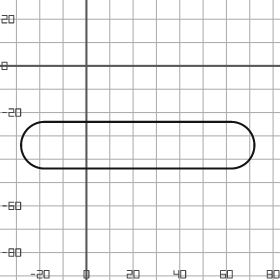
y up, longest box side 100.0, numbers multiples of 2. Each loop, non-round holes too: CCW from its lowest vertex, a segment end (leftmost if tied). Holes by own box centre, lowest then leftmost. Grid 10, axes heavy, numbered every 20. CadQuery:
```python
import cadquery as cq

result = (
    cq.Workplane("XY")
    .moveTo(-18.0, -44.0)
    .lineTo(62.0, -44.0)
    .threePointArc((72.0, -34.0), (62.0, -24.0))
    .lineTo(-18.0, -24.0)
    .threePointArc((-28.0, -34.0), (-18.0, -44.0))
    .close()
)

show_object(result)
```